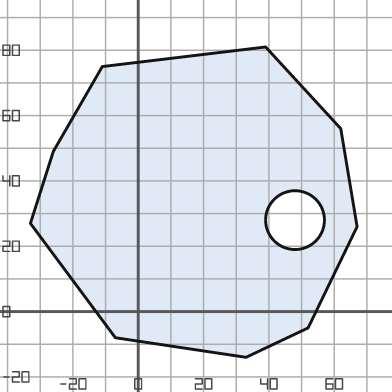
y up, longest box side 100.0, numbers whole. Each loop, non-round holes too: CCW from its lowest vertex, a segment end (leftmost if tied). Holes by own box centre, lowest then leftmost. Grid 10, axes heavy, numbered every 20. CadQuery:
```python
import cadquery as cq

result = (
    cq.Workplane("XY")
    .moveTo(33.0, -14.0)
    .lineTo(52.0, -5.0)
    .lineTo(67.0, 26.0)
    .lineTo(62.0, 56.0)
    .lineTo(39.0, 81.0)
    .lineTo(-11.0, 75.0)
    .lineTo(-26.0, 49.0)
    .lineTo(-33.0, 27.0)
    .lineTo(-7.0, -8.0)
    .close()
    .moveTo(48.0, 28.0)
    .circle(9.0)
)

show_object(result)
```